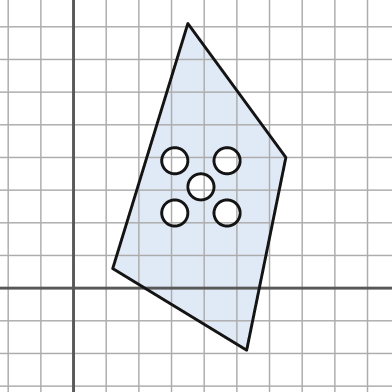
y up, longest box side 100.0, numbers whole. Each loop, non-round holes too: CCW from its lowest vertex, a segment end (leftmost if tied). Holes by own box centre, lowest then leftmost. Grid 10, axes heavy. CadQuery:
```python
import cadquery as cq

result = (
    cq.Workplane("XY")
    .moveTo(53.0, -19.0)
    .lineTo(65.0, 40.0)
    .lineTo(35.0, 81.0)
    .lineTo(12.0, 6.0)
    .close()
    .moveTo(31.0, 23.0)
    .circle(4.0)
    .moveTo(47.0, 23.0)
    .circle(4.0)
    .moveTo(39.0, 31.0)
    .circle(4.0)
    .moveTo(31.0, 39.0)
    .circle(4.0)
    .moveTo(47.0, 39.0)
    .circle(4.0)
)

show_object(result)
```